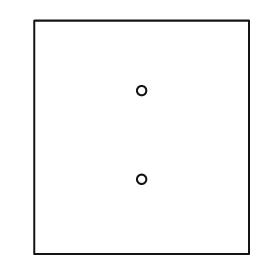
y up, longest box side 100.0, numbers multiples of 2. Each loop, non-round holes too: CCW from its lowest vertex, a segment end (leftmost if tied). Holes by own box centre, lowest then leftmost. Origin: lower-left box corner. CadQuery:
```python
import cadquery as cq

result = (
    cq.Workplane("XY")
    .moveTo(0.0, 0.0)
    .lineTo(92.0, 0.0)
    .lineTo(92.0, 100.0)
    .lineTo(0.0, 100.0)
    .close()
    .moveTo(46.0, 32.0)
    .circle(2.0)
    .moveTo(46.0, 70.0)
    .circle(2.0)
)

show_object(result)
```